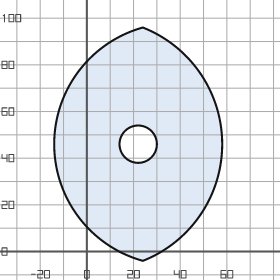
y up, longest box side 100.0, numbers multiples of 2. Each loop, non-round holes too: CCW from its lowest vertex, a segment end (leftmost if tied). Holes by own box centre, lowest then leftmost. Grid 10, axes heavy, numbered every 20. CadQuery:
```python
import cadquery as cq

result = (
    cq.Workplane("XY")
    .moveTo(24.0, -4.0)
    .threePointArc((58.0, 46.0), (24.0, 96.0))
    .threePointArc((-14.0, 46.0), (24.0, -4.0))
    .close()
    .moveTo(22.0, 46.0)
    .circle(8.0)
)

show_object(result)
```